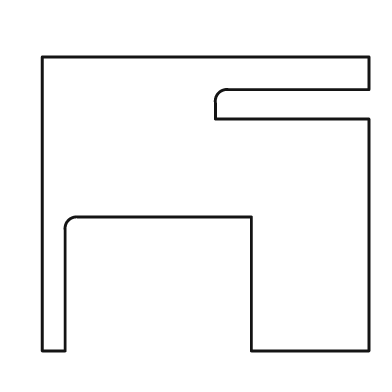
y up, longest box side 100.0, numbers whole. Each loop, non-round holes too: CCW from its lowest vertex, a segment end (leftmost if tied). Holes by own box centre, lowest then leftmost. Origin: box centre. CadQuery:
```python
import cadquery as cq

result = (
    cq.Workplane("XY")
    .moveTo(-50.0, -45.0)
    .lineTo(-43.0, -45.0)
    .lineTo(-43.0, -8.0)
    .threePointArc((-42.0, -5.0), (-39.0, -4.0))
    .lineTo(14.0, -4.0)
    .lineTo(14.0, -45.0)
    .lineTo(50.0, -45.0)
    .lineTo(50.0, 26.0)
    .lineTo(3.0, 26.0)
    .lineTo(3.0, 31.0)
    .threePointArc((4.0, 34.0), (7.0, 35.0))
    .lineTo(50.0, 35.0)
    .lineTo(50.0, 45.0)
    .lineTo(-50.0, 45.0)
    .close()
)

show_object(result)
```